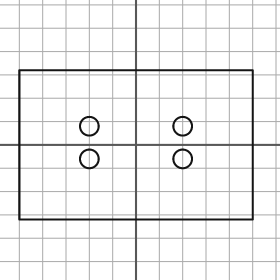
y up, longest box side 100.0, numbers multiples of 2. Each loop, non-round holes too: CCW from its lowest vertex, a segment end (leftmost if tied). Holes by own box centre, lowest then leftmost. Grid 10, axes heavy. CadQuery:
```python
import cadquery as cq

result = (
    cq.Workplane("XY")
    .moveTo(-50.0, -32.0)
    .lineTo(50.0, -32.0)
    .lineTo(50.0, 32.0)
    .lineTo(-50.0, 32.0)
    .close()
    .moveTo(-20.0, -6.0)
    .circle(4.0)
    .moveTo(20.0, -6.0)
    .circle(4.0)
    .moveTo(-20.0, 8.0)
    .circle(4.0)
    .moveTo(20.0, 8.0)
    .circle(4.0)
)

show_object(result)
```